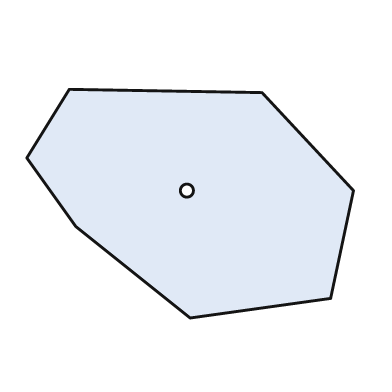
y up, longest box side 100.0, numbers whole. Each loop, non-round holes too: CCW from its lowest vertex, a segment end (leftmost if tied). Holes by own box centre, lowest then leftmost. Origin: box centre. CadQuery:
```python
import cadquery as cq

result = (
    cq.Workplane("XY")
    .moveTo(0.0, -35.0)
    .lineTo(43.0, -29.0)
    .lineTo(50.0, 4.0)
    .lineTo(22.0, 34.0)
    .lineTo(-37.0, 35.0)
    .lineTo(-50.0, 14.0)
    .lineTo(-35.0, -7.0)
    .close()
    .moveTo(-1.0, 4.0)
    .circle(2.0)
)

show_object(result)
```